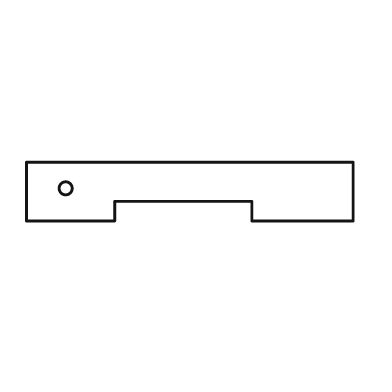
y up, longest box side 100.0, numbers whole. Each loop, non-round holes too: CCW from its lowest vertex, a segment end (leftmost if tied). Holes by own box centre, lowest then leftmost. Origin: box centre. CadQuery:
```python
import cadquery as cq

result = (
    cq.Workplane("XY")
    .moveTo(-50.0, -9.0)
    .lineTo(-23.0, -9.0)
    .lineTo(-23.0, -3.0)
    .lineTo(19.0, -3.0)
    .lineTo(19.0, -9.0)
    .lineTo(50.0, -9.0)
    .lineTo(50.0, 9.0)
    .lineTo(-50.0, 9.0)
    .close()
    .moveTo(-38.0, 1.0)
    .circle(2.0)
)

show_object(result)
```